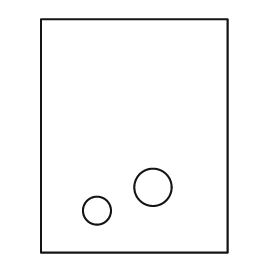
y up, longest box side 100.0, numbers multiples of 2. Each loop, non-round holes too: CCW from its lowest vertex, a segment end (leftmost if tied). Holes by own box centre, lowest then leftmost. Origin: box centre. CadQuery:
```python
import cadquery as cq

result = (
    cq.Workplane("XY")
    .moveTo(-40.0, -50.0)
    .lineTo(40.0, -50.0)
    .lineTo(40.0, 50.0)
    .lineTo(-40.0, 50.0)
    .close()
    .moveTo(-16.0, -32.0)
    .circle(6.0)
    .moveTo(8.0, -22.0)
    .circle(8.0)
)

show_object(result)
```